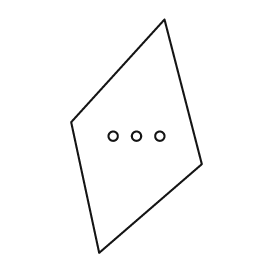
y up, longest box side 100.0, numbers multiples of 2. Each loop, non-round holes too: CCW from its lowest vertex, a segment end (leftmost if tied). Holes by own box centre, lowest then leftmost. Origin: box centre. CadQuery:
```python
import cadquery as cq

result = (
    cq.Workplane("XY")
    .moveTo(-16.0, -50.0)
    .lineTo(28.0, -12.0)
    .lineTo(12.0, 50.0)
    .lineTo(-28.0, 6.0)
    .close()
    .moveTo(-10.0, 0.0)
    .circle(2.0)
    .moveTo(0.0, 0.0)
    .circle(2.0)
    .moveTo(10.0, 0.0)
    .circle(2.0)
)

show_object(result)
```